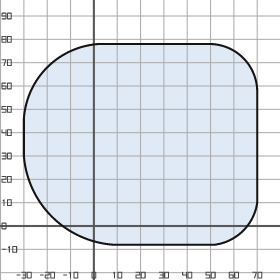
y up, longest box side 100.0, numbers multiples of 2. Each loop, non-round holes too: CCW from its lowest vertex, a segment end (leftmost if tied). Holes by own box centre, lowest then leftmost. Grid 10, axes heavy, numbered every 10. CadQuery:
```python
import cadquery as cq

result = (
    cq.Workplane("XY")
    .moveTo(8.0, -8.0)
    .lineTo(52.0, -8.0)
    .threePointArc((64.0, -2.0), (70.0, 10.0))
    .lineTo(70.0, 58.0)
    .threePointArc((64.0, 72.0), (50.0, 78.0))
    .lineTo(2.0, 78.0)
    .threePointArc((-20.0, 68.0), (-30.0, 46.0))
    .lineTo(-30.0, 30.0)
    .threePointArc((-18.0, 4.0), (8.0, -8.0))
    .close()
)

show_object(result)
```